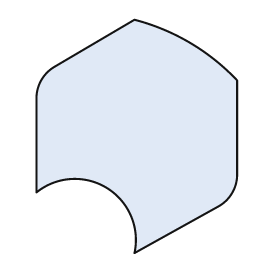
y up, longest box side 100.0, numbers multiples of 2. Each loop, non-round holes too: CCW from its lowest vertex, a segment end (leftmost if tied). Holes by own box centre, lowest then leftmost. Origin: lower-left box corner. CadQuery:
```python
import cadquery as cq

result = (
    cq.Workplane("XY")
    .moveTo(42.0, 0.0)
    .lineTo(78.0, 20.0)
    .threePointArc((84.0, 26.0), (86.0, 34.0))
    .lineTo(86.0, 74.0)
    .threePointArc((66.0, 90.0), (42.0, 100.0))
    .lineTo(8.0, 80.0)
    .threePointArc((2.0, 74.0), (0.0, 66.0))
    .lineTo(0.0, 26.0)
    .threePointArc((30.0, 28.0), (42.0, 0.0))
    .close()
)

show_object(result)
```